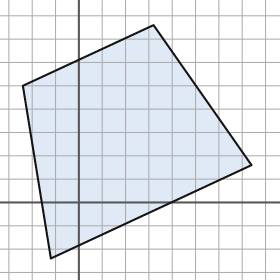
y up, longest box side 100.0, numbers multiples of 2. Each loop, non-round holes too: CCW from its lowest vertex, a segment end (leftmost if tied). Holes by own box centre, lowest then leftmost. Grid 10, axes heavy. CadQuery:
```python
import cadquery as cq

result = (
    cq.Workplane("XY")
    .moveTo(-12.0, -24.0)
    .lineTo(74.0, 16.0)
    .lineTo(32.0, 76.0)
    .lineTo(-24.0, 50.0)
    .close()
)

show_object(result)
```